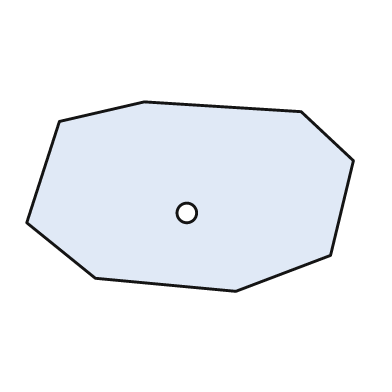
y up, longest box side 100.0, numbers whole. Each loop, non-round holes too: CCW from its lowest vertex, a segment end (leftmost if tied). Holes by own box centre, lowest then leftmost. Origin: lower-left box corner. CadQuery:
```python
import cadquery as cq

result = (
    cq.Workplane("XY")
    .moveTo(64.0, 0.0)
    .lineTo(93.0, 11.0)
    .lineTo(100.0, 40.0)
    .lineTo(84.0, 55.0)
    .lineTo(36.0, 58.0)
    .lineTo(10.0, 52.0)
    .lineTo(0.0, 21.0)
    .lineTo(21.0, 4.0)
    .close()
    .moveTo(49.0, 24.0)
    .circle(3.0)
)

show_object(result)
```